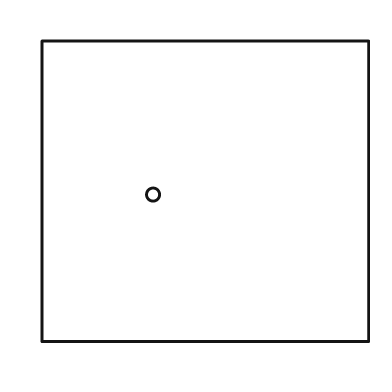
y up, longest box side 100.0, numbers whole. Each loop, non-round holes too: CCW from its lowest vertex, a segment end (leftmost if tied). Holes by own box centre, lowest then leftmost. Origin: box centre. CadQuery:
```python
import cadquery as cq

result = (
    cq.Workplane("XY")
    .moveTo(-50.0, -46.0)
    .lineTo(50.0, -46.0)
    .lineTo(50.0, 46.0)
    .lineTo(-50.0, 46.0)
    .close()
    .moveTo(-16.0, -1.0)
    .circle(2.0)
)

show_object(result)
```